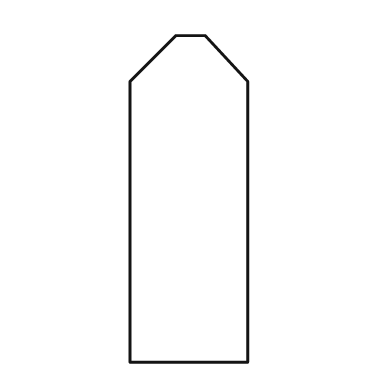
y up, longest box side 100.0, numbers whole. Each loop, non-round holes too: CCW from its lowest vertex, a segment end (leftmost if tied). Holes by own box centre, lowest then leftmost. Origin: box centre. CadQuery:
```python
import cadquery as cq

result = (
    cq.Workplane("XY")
    .moveTo(-18.0, -50.0)
    .lineTo(18.0, -50.0)
    .lineTo(18.0, 36.0)
    .lineTo(5.0, 50.0)
    .lineTo(-4.0, 50.0)
    .lineTo(-18.0, 36.0)
    .close()
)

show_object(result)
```